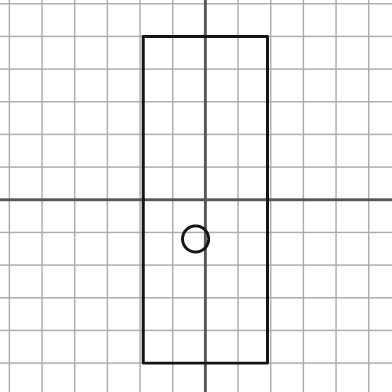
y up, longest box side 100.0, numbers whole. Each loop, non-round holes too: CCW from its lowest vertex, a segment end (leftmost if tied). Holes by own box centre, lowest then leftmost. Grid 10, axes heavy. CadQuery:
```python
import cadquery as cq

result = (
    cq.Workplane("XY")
    .moveTo(-19.0, -50.0)
    .lineTo(19.0, -50.0)
    .lineTo(19.0, 50.0)
    .lineTo(-19.0, 50.0)
    .close()
    .moveTo(-3.0, -12.0)
    .circle(4.0)
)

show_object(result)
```